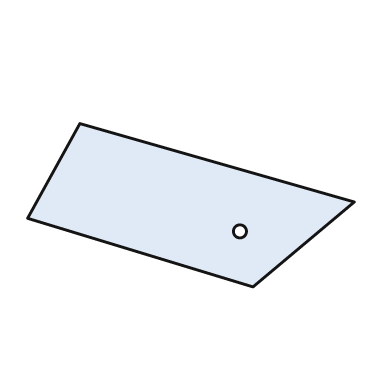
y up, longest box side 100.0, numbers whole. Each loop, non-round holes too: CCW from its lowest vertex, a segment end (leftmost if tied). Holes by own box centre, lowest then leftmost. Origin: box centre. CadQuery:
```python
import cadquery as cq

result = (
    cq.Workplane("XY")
    .moveTo(19.0, -25.0)
    .lineTo(50.0, 1.0)
    .lineTo(-34.0, 25.0)
    .lineTo(-50.0, -4.0)
    .close()
    .moveTo(15.0, -8.0)
    .circle(2.0)
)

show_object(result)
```